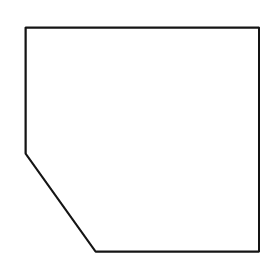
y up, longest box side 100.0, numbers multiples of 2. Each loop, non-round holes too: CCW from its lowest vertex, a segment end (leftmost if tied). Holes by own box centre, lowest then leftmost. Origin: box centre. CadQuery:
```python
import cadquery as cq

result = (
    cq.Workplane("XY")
    .moveTo(-20.0, -48.0)
    .lineTo(50.0, -48.0)
    .lineTo(50.0, 48.0)
    .lineTo(-50.0, 48.0)
    .lineTo(-50.0, -6.0)
    .close()
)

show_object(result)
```